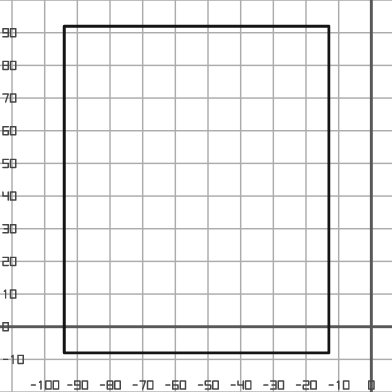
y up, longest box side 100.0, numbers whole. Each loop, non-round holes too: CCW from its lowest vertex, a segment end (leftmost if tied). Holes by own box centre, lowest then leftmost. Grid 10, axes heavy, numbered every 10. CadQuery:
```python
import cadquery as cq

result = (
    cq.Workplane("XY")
    .moveTo(-94.0, -8.0)
    .lineTo(-13.0, -8.0)
    .lineTo(-13.0, 92.0)
    .lineTo(-94.0, 92.0)
    .close()
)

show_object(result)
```